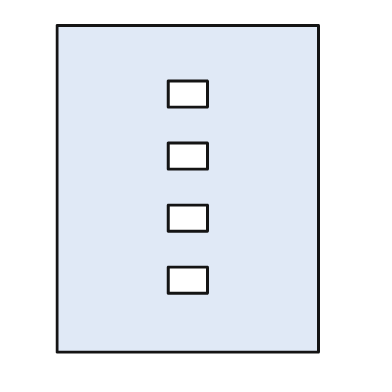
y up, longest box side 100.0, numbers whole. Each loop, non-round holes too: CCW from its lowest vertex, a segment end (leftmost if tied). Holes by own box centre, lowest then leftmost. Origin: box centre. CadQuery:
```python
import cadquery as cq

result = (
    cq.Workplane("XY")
    .moveTo(-40.0, -50.0)
    .lineTo(40.0, -50.0)
    .lineTo(40.0, 50.0)
    .lineTo(-40.0, 50.0)
    .close()
    .moveTo(-6.0, -32.0)
    .lineTo(6.0, -32.0)
    .lineTo(6.0, -24.0)
    .lineTo(-6.0, -24.0)
    .close()
    .moveTo(-6.0, -13.0)
    .lineTo(6.0, -13.0)
    .lineTo(6.0, -5.0)
    .lineTo(-6.0, -5.0)
    .close()
    .moveTo(-6.0, 6.0)
    .lineTo(6.0, 6.0)
    .lineTo(6.0, 14.0)
    .lineTo(-6.0, 14.0)
    .close()
    .moveTo(-6.0, 25.0)
    .lineTo(6.0, 25.0)
    .lineTo(6.0, 33.0)
    .lineTo(-6.0, 33.0)
    .close()
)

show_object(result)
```